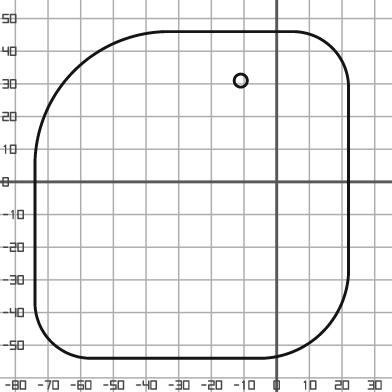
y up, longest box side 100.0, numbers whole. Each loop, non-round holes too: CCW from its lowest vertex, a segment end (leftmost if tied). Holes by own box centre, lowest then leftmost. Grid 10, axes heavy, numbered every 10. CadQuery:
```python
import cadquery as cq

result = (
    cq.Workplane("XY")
    .moveTo(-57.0, -54.0)
    .lineTo(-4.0, -54.0)
    .threePointArc((14.0, -46.0), (22.0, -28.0))
    .lineTo(22.0, 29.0)
    .threePointArc((17.0, 41.0), (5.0, 46.0))
    .lineTo(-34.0, 46.0)
    .threePointArc((-62.0, 34.0), (-74.0, 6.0))
    .lineTo(-74.0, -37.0)
    .threePointArc((-69.0, -49.0), (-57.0, -54.0))
    .close()
    .moveTo(-11.0, 31.0)
    .circle(2.0)
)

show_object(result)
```